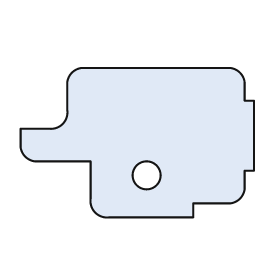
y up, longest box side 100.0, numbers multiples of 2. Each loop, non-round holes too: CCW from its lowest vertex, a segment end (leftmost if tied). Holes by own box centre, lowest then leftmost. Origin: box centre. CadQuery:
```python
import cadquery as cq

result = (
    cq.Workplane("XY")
    .moveTo(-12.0, -32.0)
    .lineTo(24.0, -32.0)
    .lineTo(24.0, -26.0)
    .lineTo(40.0, -26.0)
    .threePointArc((44.0, -24.0), (46.0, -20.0))
    .lineTo(46.0, -12.0)
    .lineTo(50.0, -12.0)
    .lineTo(50.0, 18.0)
    .lineTo(46.0, 18.0)
    .lineTo(46.0, 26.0)
    .threePointArc((44.0, 30.0), (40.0, 32.0))
    .lineTo(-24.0, 32.0)
    .threePointArc((-28.0, 30.0), (-30.0, 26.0))
    .lineTo(-30.0, 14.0)
    .threePointArc((-32.0, 8.0), (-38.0, 6.0))
    .lineTo(-50.0, 6.0)
    .lineTo(-50.0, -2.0)
    .threePointArc((-48.0, -6.0), (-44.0, -8.0))
    .lineTo(-20.0, -8.0)
    .lineTo(-20.0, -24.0)
    .threePointArc((-18.0, -30.0), (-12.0, -32.0))
    .close()
    .moveTo(4.0, -14.0)
    .circle(6.0)
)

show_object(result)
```